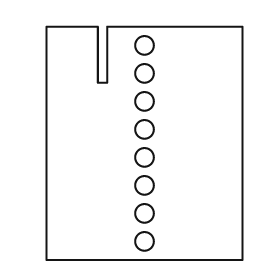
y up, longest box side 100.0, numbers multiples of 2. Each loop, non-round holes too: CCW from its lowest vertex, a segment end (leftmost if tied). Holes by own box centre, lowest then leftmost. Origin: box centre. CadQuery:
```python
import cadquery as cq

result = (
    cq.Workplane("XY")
    .moveTo(-42.0, -50.0)
    .lineTo(42.0, -50.0)
    .lineTo(42.0, 50.0)
    .lineTo(-16.0, 50.0)
    .lineTo(-16.0, 26.0)
    .lineTo(-20.0, 26.0)
    .lineTo(-20.0, 50.0)
    .lineTo(-42.0, 50.0)
    .close()
    .moveTo(0.0, -42.0)
    .circle(4.0)
    .moveTo(0.0, -30.0)
    .circle(4.0)
    .moveTo(0.0, -18.0)
    .circle(4.0)
    .moveTo(0.0, -6.0)
    .circle(4.0)
    .moveTo(0.0, 6.0)
    .circle(4.0)
    .moveTo(0.0, 18.0)
    .circle(4.0)
    .moveTo(0.0, 30.0)
    .circle(4.0)
    .moveTo(0.0, 42.0)
    .circle(4.0)
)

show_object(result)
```